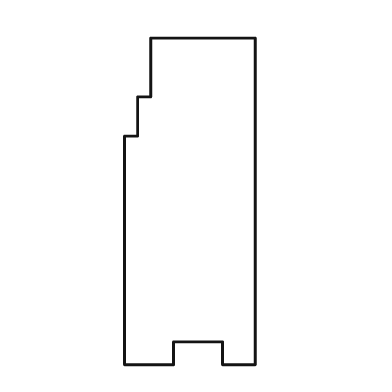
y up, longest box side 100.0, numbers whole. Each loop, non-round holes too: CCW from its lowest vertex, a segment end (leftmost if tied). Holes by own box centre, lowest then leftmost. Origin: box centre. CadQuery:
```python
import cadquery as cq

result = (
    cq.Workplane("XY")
    .moveTo(-20.0, -50.0)
    .lineTo(-5.0, -50.0)
    .lineTo(-5.0, -43.0)
    .lineTo(10.0, -43.0)
    .lineTo(10.0, -50.0)
    .lineTo(20.0, -50.0)
    .lineTo(20.0, 50.0)
    .lineTo(-12.0, 50.0)
    .lineTo(-12.0, 32.0)
    .lineTo(-16.0, 32.0)
    .lineTo(-16.0, 20.0)
    .lineTo(-20.0, 20.0)
    .close()
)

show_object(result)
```